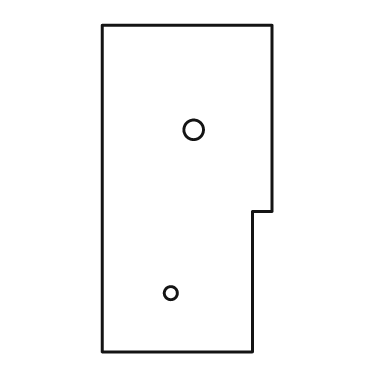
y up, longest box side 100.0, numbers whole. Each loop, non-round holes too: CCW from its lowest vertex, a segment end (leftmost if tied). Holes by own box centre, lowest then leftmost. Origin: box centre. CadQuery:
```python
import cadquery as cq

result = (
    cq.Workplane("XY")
    .moveTo(-26.0, -50.0)
    .lineTo(20.0, -50.0)
    .lineTo(20.0, -7.0)
    .lineTo(26.0, -7.0)
    .lineTo(26.0, 50.0)
    .lineTo(-26.0, 50.0)
    .close()
    .moveTo(-5.0, -32.0)
    .circle(2.0)
    .moveTo(2.0, 18.0)
    .circle(3.0)
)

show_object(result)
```